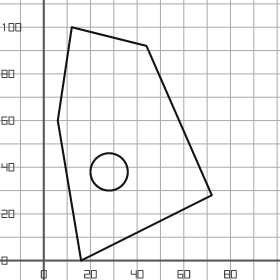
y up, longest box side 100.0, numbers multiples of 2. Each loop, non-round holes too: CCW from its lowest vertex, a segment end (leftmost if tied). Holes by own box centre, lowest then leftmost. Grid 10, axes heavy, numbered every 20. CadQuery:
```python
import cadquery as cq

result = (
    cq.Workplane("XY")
    .moveTo(16.0, 0.0)
    .lineTo(72.0, 28.0)
    .lineTo(44.0, 92.0)
    .lineTo(12.0, 100.0)
    .lineTo(6.0, 60.0)
    .close()
    .moveTo(28.0, 38.0)
    .circle(8.0)
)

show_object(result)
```